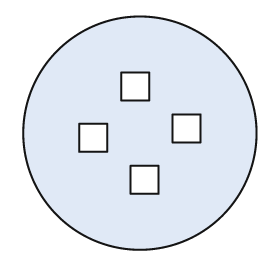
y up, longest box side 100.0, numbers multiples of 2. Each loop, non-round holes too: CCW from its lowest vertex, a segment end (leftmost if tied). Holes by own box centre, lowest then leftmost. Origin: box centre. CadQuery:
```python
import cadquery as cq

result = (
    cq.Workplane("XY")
    .moveTo(0.0, 0.0)
    .circle(50.0)
    .moveTo(-4.0, -26.0)
    .lineTo(8.0, -26.0)
    .lineTo(8.0, -14.0)
    .lineTo(-4.0, -14.0)
    .close()
    .moveTo(-26.0, -8.0)
    .lineTo(-14.0, -8.0)
    .lineTo(-14.0, 4.0)
    .lineTo(-26.0, 4.0)
    .close()
    .moveTo(14.0, -4.0)
    .lineTo(26.0, -4.0)
    .lineTo(26.0, 8.0)
    .lineTo(14.0, 8.0)
    .close()
    .moveTo(-8.0, 14.0)
    .lineTo(4.0, 14.0)
    .lineTo(4.0, 26.0)
    .lineTo(-8.0, 26.0)
    .close()
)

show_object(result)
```